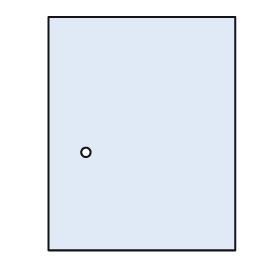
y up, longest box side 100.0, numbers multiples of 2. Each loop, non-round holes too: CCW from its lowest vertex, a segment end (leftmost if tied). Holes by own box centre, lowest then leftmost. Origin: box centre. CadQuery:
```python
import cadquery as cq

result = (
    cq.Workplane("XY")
    .moveTo(-40.0, -50.0)
    .lineTo(40.0, -50.0)
    .lineTo(40.0, 50.0)
    .lineTo(-40.0, 50.0)
    .close()
    .moveTo(-24.0, -8.0)
    .circle(2.0)
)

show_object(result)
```